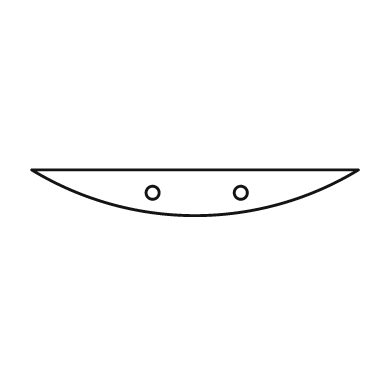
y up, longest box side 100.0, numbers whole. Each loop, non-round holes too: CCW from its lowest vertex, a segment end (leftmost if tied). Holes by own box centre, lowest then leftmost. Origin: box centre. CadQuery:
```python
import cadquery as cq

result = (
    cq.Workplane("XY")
    .moveTo(-50.0, 7.0)
    .threePointArc((0.0, -7.0), (50.0, 7.0))
    .close()
    .moveTo(-13.0, 0.0)
    .circle(2.0)
    .moveTo(14.0, 0.0)
    .circle(2.0)
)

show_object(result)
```